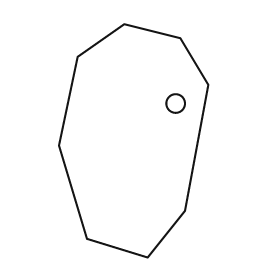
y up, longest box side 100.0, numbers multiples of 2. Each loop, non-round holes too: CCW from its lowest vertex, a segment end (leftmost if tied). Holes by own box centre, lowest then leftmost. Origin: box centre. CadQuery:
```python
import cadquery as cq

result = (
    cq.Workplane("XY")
    .moveTo(6.0, -50.0)
    .lineTo(22.0, -30.0)
    .lineTo(32.0, 24.0)
    .lineTo(20.0, 44.0)
    .lineTo(-4.0, 50.0)
    .lineTo(-24.0, 36.0)
    .lineTo(-32.0, -2.0)
    .lineTo(-20.0, -42.0)
    .close()
    .moveTo(18.0, 16.0)
    .circle(4.0)
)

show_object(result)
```